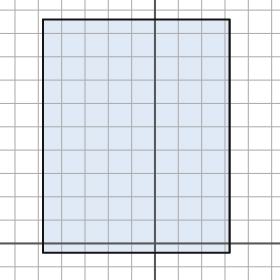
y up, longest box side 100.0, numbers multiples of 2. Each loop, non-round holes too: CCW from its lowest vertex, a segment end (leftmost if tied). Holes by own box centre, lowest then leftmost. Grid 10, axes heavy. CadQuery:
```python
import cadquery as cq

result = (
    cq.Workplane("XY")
    .moveTo(-48.0, -4.0)
    .lineTo(32.0, -4.0)
    .lineTo(32.0, 96.0)
    .lineTo(-48.0, 96.0)
    .close()
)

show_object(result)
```